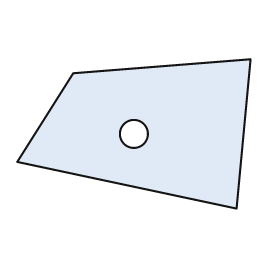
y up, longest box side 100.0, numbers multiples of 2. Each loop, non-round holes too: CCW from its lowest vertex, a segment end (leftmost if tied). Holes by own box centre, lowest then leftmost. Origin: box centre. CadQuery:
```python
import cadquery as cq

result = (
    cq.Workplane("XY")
    .moveTo(44.0, -32.0)
    .lineTo(50.0, 32.0)
    .lineTo(-26.0, 26.0)
    .lineTo(-50.0, -12.0)
    .close()
    .moveTo(0.0, 0.0)
    .circle(6.0)
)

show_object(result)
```